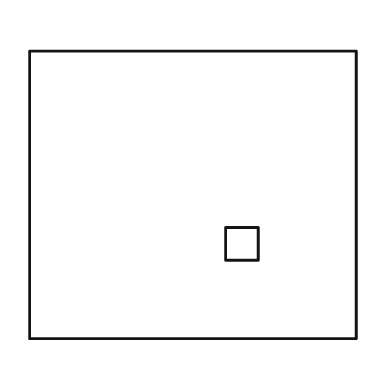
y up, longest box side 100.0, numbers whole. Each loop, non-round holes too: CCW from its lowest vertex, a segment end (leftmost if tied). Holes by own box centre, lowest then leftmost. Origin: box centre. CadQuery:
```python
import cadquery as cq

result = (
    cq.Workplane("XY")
    .moveTo(-50.0, -44.0)
    .lineTo(50.0, -44.0)
    .lineTo(50.0, 44.0)
    .lineTo(-50.0, 44.0)
    .close()
    .moveTo(10.0, -20.0)
    .lineTo(20.0, -20.0)
    .lineTo(20.0, -10.0)
    .lineTo(10.0, -10.0)
    .close()
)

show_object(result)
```